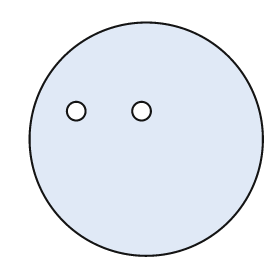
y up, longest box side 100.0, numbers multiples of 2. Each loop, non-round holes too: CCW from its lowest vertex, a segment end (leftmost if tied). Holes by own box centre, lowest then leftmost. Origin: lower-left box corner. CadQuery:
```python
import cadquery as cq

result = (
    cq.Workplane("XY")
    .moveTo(50.0, 50.0)
    .circle(50.0)
    .moveTo(20.0, 62.0)
    .circle(4.0)
    .moveTo(48.0, 62.0)
    .circle(4.0)
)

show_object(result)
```